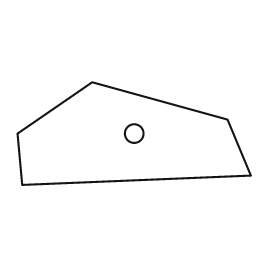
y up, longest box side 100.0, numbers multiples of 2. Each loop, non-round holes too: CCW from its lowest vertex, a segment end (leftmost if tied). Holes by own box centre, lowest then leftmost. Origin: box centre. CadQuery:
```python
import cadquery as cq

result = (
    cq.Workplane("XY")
    .moveTo(-48.0, -22.0)
    .lineTo(50.0, -18.0)
    .lineTo(40.0, 6.0)
    .lineTo(-18.0, 22.0)
    .lineTo(-50.0, 0.0)
    .close()
    .moveTo(0.0, 0.0)
    .circle(4.0)
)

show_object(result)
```